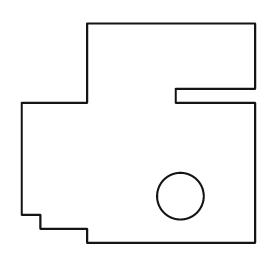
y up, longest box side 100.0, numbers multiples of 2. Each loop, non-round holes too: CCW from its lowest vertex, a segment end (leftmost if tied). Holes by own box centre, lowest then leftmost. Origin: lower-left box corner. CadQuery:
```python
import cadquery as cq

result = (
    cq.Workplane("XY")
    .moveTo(28.0, 0.0)
    .lineTo(100.0, 0.0)
    .lineTo(100.0, 60.0)
    .lineTo(66.0, 60.0)
    .lineTo(66.0, 66.0)
    .lineTo(100.0, 66.0)
    .lineTo(100.0, 94.0)
    .lineTo(28.0, 94.0)
    .lineTo(28.0, 60.0)
    .lineTo(0.0, 60.0)
    .lineTo(0.0, 12.0)
    .lineTo(8.0, 12.0)
    .lineTo(8.0, 6.0)
    .lineTo(28.0, 6.0)
    .close()
    .moveTo(68.0, 20.0)
    .circle(10.0)
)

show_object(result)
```